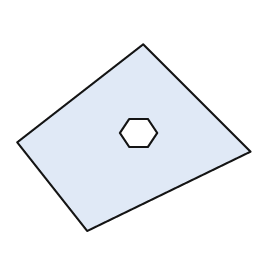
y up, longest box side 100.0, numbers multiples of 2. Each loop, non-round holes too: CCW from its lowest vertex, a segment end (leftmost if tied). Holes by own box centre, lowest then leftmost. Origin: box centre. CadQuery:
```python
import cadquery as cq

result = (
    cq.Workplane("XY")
    .moveTo(-20.0, -40.0)
    .lineTo(50.0, -6.0)
    .lineTo(4.0, 40.0)
    .lineTo(-50.0, -2.0)
    .close()
    .moveTo(-2.0, -4.0)
    .lineTo(6.0, -4.0)
    .lineTo(10.0, 2.0)
    .lineTo(6.0, 8.0)
    .lineTo(-2.0, 8.0)
    .lineTo(-6.0, 2.0)
    .close()
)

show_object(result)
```